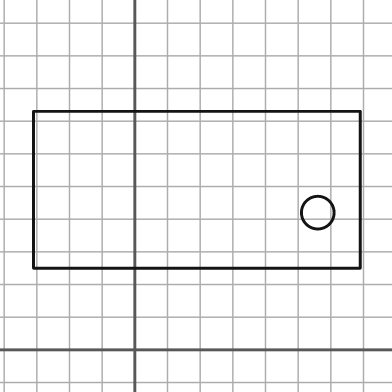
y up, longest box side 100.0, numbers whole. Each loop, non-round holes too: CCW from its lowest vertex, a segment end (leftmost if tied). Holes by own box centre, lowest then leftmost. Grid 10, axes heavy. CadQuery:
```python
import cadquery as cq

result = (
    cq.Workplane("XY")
    .moveTo(-31.0, 25.0)
    .lineTo(69.0, 25.0)
    .lineTo(69.0, 73.0)
    .lineTo(-31.0, 73.0)
    .close()
    .moveTo(56.0, 42.0)
    .circle(5.0)
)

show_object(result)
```